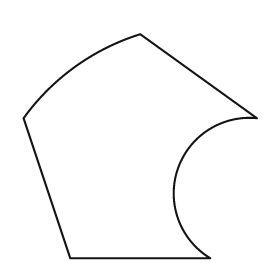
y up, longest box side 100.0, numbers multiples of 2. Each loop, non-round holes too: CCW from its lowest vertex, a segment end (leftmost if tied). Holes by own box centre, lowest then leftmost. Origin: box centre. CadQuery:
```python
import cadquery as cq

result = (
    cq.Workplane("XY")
    .moveTo(-30.0, -48.0)
    .lineTo(30.0, -48.0)
    .threePointArc((16.0, -10.0), (50.0, 12.0))
    .lineTo(0.0, 48.0)
    .threePointArc((-28.0, 34.0), (-50.0, 12.0))
    .close()
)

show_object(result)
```